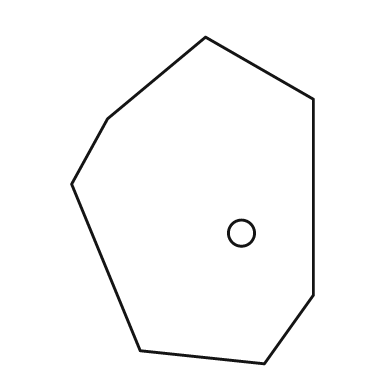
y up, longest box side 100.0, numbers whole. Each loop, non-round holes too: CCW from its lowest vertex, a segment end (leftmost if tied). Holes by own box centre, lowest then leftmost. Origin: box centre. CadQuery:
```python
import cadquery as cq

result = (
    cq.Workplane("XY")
    .moveTo(22.0, -50.0)
    .lineTo(37.0, -29.0)
    .lineTo(37.0, 31.0)
    .lineTo(4.0, 50.0)
    .lineTo(-26.0, 25.0)
    .lineTo(-37.0, 5.0)
    .lineTo(-16.0, -46.0)
    .close()
    .moveTo(15.0, -10.0)
    .circle(4.0)
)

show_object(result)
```